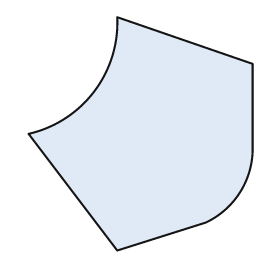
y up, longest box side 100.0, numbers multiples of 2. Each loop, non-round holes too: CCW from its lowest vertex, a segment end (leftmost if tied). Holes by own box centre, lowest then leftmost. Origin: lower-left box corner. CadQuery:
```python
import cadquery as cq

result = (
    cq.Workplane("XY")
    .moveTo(38.0, 0.0)
    .lineTo(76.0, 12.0)
    .threePointArc((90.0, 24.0), (96.0, 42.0))
    .lineTo(96.0, 80.0)
    .lineTo(38.0, 100.0)
    .threePointArc((28.0, 68.0), (0.0, 50.0))
    .close()
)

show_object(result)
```